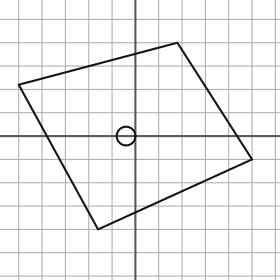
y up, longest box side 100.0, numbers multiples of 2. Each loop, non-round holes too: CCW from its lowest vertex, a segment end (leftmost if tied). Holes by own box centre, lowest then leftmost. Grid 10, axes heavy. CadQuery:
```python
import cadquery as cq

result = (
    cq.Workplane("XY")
    .moveTo(-16.0, -40.0)
    .lineTo(50.0, -10.0)
    .lineTo(18.0, 40.0)
    .lineTo(-50.0, 22.0)
    .close()
    .moveTo(-4.0, 0.0)
    .circle(4.0)
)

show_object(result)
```